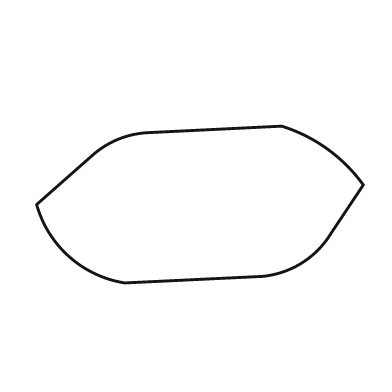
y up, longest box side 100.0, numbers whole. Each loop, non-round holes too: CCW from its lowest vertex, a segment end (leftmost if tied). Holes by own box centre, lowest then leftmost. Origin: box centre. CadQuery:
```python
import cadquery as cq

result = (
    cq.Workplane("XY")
    .moveTo(-23.0, -24.0)
    .lineTo(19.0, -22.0)
    .threePointArc((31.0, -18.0), (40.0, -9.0))
    .lineTo(50.0, 6.0)
    .threePointArc((39.0, 17.0), (25.0, 24.0))
    .lineTo(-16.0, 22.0)
    .threePointArc((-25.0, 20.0), (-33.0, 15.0))
    .lineTo(-50.0, 0.0)
    .threePointArc((-40.0, -16.0), (-23.0, -24.0))
    .close()
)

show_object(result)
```